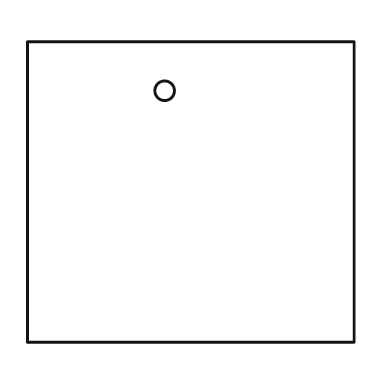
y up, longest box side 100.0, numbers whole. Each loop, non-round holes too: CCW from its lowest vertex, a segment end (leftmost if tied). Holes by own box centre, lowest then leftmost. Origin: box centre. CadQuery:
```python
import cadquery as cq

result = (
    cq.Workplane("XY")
    .moveTo(-50.0, -46.0)
    .lineTo(50.0, -46.0)
    .lineTo(50.0, 46.0)
    .lineTo(-50.0, 46.0)
    .close()
    .moveTo(-8.0, 31.0)
    .circle(3.0)
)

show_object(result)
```